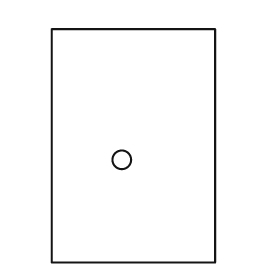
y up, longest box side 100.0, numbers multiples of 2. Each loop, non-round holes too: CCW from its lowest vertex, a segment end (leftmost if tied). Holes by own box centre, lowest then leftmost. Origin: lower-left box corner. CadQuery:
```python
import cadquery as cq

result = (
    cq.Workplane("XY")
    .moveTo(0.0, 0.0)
    .lineTo(70.0, 0.0)
    .lineTo(70.0, 100.0)
    .lineTo(0.0, 100.0)
    .close()
    .moveTo(30.0, 44.0)
    .circle(4.0)
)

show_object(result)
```